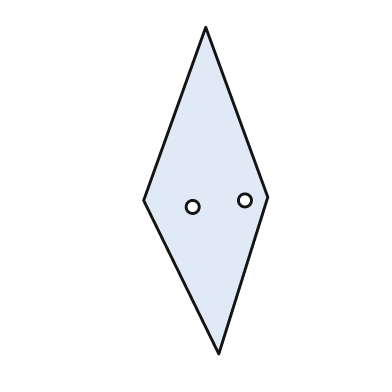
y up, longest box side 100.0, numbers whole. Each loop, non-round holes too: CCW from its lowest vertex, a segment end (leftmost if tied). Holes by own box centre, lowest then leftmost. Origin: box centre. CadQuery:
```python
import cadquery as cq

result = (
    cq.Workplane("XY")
    .moveTo(4.0, -50.0)
    .lineTo(19.0, -2.0)
    .lineTo(0.0, 50.0)
    .lineTo(-19.0, -3.0)
    .close()
    .moveTo(-4.0, -5.0)
    .circle(2.0)
    .moveTo(12.0, -3.0)
    .circle(2.0)
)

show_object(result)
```